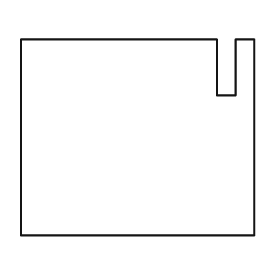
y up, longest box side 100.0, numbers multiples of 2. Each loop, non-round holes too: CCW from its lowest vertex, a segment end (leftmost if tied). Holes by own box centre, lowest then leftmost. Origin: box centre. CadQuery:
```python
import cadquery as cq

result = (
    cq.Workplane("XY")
    .moveTo(-50.0, -42.0)
    .lineTo(50.0, -42.0)
    .lineTo(50.0, 42.0)
    .lineTo(42.0, 42.0)
    .lineTo(42.0, 18.0)
    .lineTo(34.0, 18.0)
    .lineTo(34.0, 42.0)
    .lineTo(-50.0, 42.0)
    .close()
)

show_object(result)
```